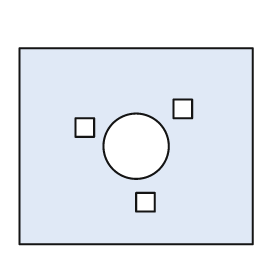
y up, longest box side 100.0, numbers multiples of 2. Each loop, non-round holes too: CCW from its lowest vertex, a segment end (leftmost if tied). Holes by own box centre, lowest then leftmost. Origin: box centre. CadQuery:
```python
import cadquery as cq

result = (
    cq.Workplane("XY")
    .moveTo(-50.0, -42.0)
    .lineTo(50.0, -42.0)
    .lineTo(50.0, 42.0)
    .lineTo(-50.0, 42.0)
    .close()
    .moveTo(0.0, -28.0)
    .lineTo(8.0, -28.0)
    .lineTo(8.0, -20.0)
    .lineTo(0.0, -20.0)
    .close()
    .moveTo(0.0, 0.0)
    .circle(14.0)
    .moveTo(-26.0, 4.0)
    .lineTo(-18.0, 4.0)
    .lineTo(-18.0, 12.0)
    .lineTo(-26.0, 12.0)
    .close()
    .moveTo(16.0, 12.0)
    .lineTo(24.0, 12.0)
    .lineTo(24.0, 20.0)
    .lineTo(16.0, 20.0)
    .close()
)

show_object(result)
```